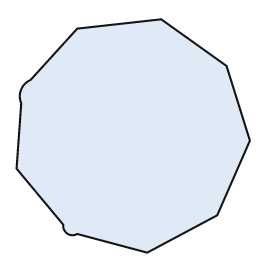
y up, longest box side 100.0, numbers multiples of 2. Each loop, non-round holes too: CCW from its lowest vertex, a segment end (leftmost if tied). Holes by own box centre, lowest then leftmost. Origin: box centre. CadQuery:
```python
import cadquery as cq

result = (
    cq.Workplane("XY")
    .moveTo(6.0, -50.0)
    .lineTo(36.0, -34.0)
    .lineTo(50.0, -2.0)
    .lineTo(40.0, 30.0)
    .lineTo(12.0, 50.0)
    .lineTo(-24.0, 46.0)
    .lineTo(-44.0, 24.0)
    .threePointArc((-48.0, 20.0), (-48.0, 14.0))
    .lineTo(-50.0, -14.0)
    .lineTo(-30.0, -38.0)
    .threePointArc((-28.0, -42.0), (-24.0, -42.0))
    .close()
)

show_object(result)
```